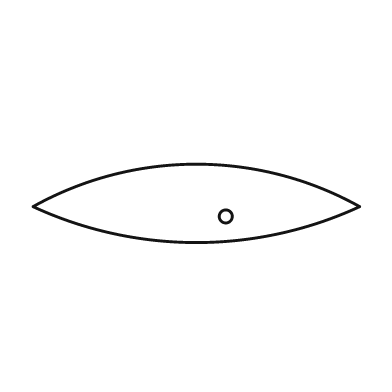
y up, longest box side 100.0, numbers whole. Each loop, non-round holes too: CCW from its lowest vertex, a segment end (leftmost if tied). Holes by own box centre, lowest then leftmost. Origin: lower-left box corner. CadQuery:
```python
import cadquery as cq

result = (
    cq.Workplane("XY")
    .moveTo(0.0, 11.0)
    .threePointArc((50.0, 0.0), (100.0, 11.0))
    .threePointArc((50.0, 24.0), (0.0, 11.0))
    .close()
    .moveTo(59.0, 8.0)
    .circle(2.0)
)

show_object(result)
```